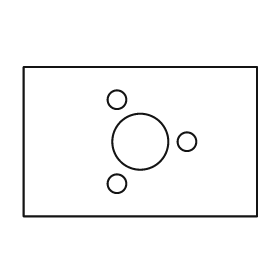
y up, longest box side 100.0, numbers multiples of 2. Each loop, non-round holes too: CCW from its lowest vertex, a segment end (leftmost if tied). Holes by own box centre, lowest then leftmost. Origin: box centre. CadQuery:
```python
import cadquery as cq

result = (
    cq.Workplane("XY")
    .moveTo(-50.0, -32.0)
    .lineTo(50.0, -32.0)
    .lineTo(50.0, 32.0)
    .lineTo(-50.0, 32.0)
    .close()
    .moveTo(-10.0, -18.0)
    .circle(4.0)
    .moveTo(0.0, 0.0)
    .circle(12.0)
    .moveTo(20.0, 0.0)
    .circle(4.0)
    .moveTo(-10.0, 18.0)
    .circle(4.0)
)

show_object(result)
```